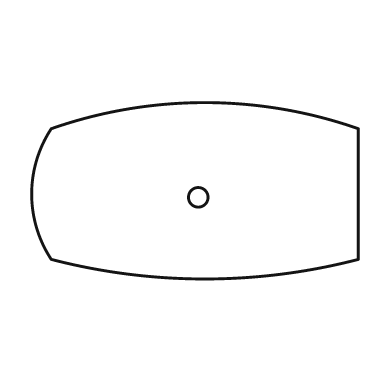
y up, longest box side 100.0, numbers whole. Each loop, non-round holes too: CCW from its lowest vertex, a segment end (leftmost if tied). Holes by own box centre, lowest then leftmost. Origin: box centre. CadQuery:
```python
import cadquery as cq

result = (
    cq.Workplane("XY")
    .moveTo(-44.0, -21.0)
    .threePointArc((3.0, -27.0), (50.0, -21.0))
    .lineTo(50.0, 19.0)
    .threePointArc((3.0, 27.0), (-44.0, 19.0))
    .threePointArc((-50.0, -1.0), (-44.0, -21.0))
    .close()
    .moveTo(1.0, -2.0)
    .circle(3.0)
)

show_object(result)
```